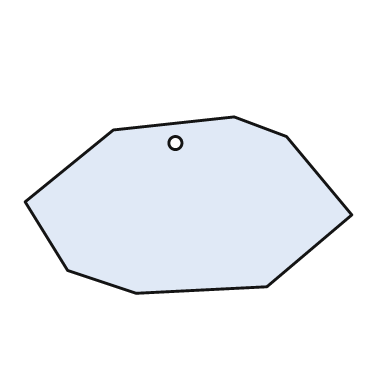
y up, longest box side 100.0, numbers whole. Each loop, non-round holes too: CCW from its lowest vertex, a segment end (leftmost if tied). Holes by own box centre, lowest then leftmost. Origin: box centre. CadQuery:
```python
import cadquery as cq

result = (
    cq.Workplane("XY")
    .moveTo(-16.0, -27.0)
    .lineTo(24.0, -25.0)
    .lineTo(50.0, -3.0)
    .lineTo(30.0, 21.0)
    .lineTo(14.0, 27.0)
    .lineTo(-23.0, 23.0)
    .lineTo(-50.0, 1.0)
    .lineTo(-37.0, -20.0)
    .close()
    .moveTo(-4.0, 19.0)
    .circle(2.0)
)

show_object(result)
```